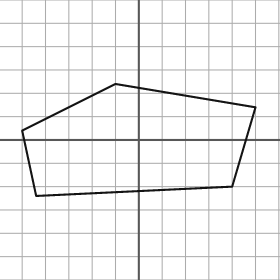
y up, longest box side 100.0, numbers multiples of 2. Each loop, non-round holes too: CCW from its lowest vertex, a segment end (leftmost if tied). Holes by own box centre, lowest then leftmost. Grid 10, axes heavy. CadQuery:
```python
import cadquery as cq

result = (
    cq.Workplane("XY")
    .moveTo(-44.0, -24.0)
    .lineTo(40.0, -20.0)
    .lineTo(50.0, 14.0)
    .lineTo(-10.0, 24.0)
    .lineTo(-50.0, 4.0)
    .close()
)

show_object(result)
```